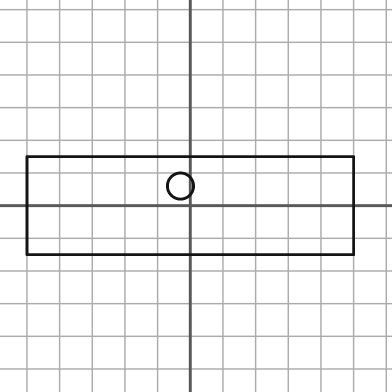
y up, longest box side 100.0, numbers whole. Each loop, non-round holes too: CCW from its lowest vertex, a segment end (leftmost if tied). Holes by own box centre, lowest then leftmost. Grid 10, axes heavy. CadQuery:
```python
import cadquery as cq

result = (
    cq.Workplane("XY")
    .moveTo(-50.0, -15.0)
    .lineTo(50.0, -15.0)
    .lineTo(50.0, 15.0)
    .lineTo(-50.0, 15.0)
    .close()
    .moveTo(-3.0, 6.0)
    .circle(4.0)
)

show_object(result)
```